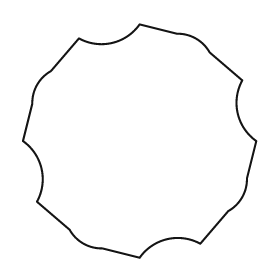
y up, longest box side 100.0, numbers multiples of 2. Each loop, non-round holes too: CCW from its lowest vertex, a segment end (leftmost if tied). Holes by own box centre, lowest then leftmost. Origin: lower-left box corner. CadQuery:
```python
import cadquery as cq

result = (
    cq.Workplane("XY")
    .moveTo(50.0, 0.0)
    .threePointArc((62.0, 8.0), (76.0, 6.0))
    .lineTo(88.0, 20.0)
    .threePointArc((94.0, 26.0), (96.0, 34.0))
    .lineTo(100.0, 50.0)
    .threePointArc((92.0, 62.0), (94.0, 76.0))
    .lineTo(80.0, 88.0)
    .threePointArc((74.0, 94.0), (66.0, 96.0))
    .lineTo(50.0, 100.0)
    .threePointArc((38.0, 92.0), (24.0, 94.0))
    .lineTo(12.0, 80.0)
    .threePointArc((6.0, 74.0), (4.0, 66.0))
    .lineTo(0.0, 50.0)
    .threePointArc((8.0, 38.0), (6.0, 24.0))
    .lineTo(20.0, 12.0)
    .threePointArc((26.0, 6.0), (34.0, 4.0))
    .close()
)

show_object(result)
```